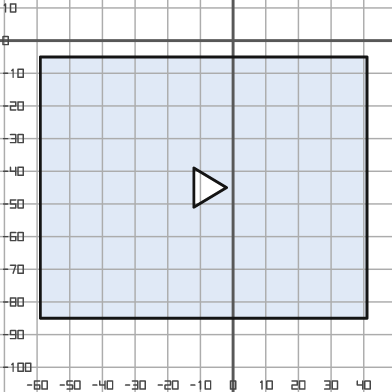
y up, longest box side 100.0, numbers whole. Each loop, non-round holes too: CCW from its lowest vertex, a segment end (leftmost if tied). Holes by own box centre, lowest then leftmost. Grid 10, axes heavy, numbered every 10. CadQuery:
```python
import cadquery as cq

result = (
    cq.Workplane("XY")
    .moveTo(-59.0, -85.0)
    .lineTo(41.0, -85.0)
    .lineTo(41.0, -5.0)
    .lineTo(-59.0, -5.0)
    .close()
    .moveTo(-12.0, -51.0)
    .lineTo(-2.0, -45.0)
    .lineTo(-12.0, -39.0)
    .close()
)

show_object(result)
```